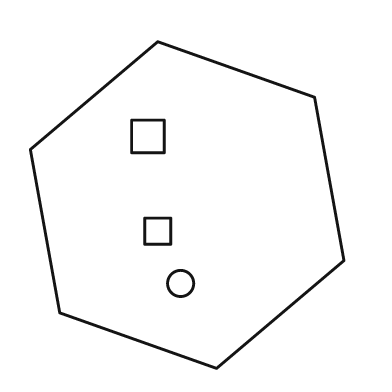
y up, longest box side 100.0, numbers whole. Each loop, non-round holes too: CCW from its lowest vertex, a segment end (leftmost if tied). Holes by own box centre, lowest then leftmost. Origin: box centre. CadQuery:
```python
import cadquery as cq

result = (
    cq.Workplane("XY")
    .moveTo(9.0, -50.0)
    .lineTo(48.0, -17.0)
    .lineTo(39.0, 33.0)
    .lineTo(-9.0, 50.0)
    .lineTo(-48.0, 17.0)
    .lineTo(-39.0, -33.0)
    .close()
    .moveTo(-2.0, -24.0)
    .circle(4.0)
    .moveTo(-13.0, -12.0)
    .lineTo(-5.0, -12.0)
    .lineTo(-5.0, -4.0)
    .lineTo(-13.0, -4.0)
    .close()
    .moveTo(-17.0, 16.0)
    .lineTo(-7.0, 16.0)
    .lineTo(-7.0, 26.0)
    .lineTo(-17.0, 26.0)
    .close()
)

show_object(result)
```